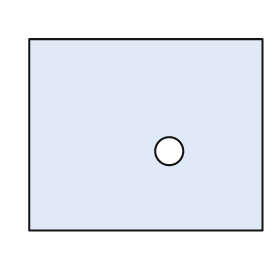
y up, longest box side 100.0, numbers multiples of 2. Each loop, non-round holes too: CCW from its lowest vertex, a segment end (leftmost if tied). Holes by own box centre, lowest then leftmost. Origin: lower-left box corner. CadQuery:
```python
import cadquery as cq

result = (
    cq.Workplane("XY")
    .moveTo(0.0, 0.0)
    .lineTo(100.0, 0.0)
    .lineTo(100.0, 82.0)
    .lineTo(0.0, 82.0)
    .close()
    .moveTo(60.0, 34.0)
    .circle(6.0)
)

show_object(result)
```